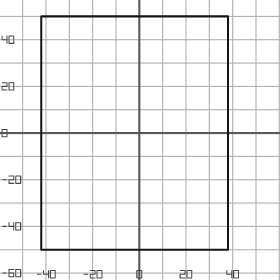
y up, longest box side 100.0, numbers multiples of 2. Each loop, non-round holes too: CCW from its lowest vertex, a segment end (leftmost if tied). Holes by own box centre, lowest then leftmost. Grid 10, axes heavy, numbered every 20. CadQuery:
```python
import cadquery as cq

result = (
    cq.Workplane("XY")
    .moveTo(-42.0, -50.0)
    .lineTo(38.0, -50.0)
    .lineTo(38.0, 50.0)
    .lineTo(-42.0, 50.0)
    .close()
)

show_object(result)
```